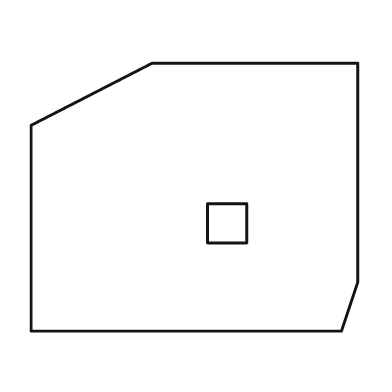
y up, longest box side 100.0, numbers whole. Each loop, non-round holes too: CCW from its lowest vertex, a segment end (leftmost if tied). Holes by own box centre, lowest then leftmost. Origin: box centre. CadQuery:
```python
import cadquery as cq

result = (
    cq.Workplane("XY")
    .moveTo(-50.0, -41.0)
    .lineTo(45.0, -41.0)
    .lineTo(50.0, -26.0)
    .lineTo(50.0, 41.0)
    .lineTo(-13.0, 41.0)
    .lineTo(-50.0, 22.0)
    .close()
    .moveTo(4.0, -14.0)
    .lineTo(16.0, -14.0)
    .lineTo(16.0, -2.0)
    .lineTo(4.0, -2.0)
    .close()
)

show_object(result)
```